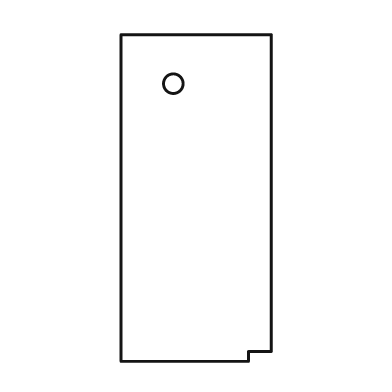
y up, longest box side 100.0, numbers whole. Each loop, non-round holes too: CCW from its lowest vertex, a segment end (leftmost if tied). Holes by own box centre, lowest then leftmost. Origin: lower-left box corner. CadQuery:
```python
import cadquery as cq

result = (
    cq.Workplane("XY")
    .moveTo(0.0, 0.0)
    .lineTo(39.0, 0.0)
    .lineTo(39.0, 3.0)
    .lineTo(46.0, 3.0)
    .lineTo(46.0, 100.0)
    .lineTo(0.0, 100.0)
    .close()
    .moveTo(16.0, 85.0)
    .circle(3.0)
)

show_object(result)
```